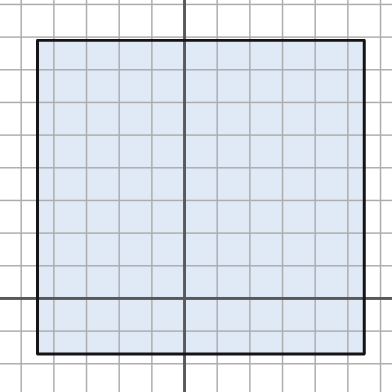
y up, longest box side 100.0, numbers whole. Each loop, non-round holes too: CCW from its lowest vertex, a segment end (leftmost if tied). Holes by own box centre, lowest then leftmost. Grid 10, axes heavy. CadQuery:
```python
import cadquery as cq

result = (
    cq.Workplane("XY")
    .moveTo(-45.0, -17.0)
    .lineTo(55.0, -17.0)
    .lineTo(55.0, 79.0)
    .lineTo(-45.0, 79.0)
    .close()
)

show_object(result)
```